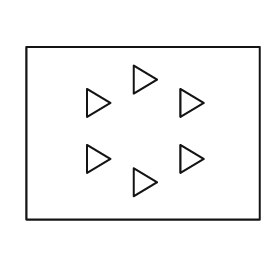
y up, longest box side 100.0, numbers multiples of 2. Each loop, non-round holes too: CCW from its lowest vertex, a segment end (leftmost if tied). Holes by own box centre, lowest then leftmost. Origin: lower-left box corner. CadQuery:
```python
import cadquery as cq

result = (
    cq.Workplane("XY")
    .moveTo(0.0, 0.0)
    .lineTo(100.0, 0.0)
    .lineTo(100.0, 74.0)
    .lineTo(0.0, 74.0)
    .close()
    .moveTo(46.0, 10.0)
    .lineTo(56.0, 16.0)
    .lineTo(46.0, 22.0)
    .close()
    .moveTo(26.0, 20.0)
    .lineTo(36.0, 26.0)
    .lineTo(26.0, 32.0)
    .close()
    .moveTo(66.0, 20.0)
    .lineTo(76.0, 26.0)
    .lineTo(66.0, 32.0)
    .close()
    .moveTo(26.0, 44.0)
    .lineTo(36.0, 50.0)
    .lineTo(26.0, 56.0)
    .close()
    .moveTo(66.0, 44.0)
    .lineTo(76.0, 50.0)
    .lineTo(66.0, 56.0)
    .close()
    .moveTo(46.0, 54.0)
    .lineTo(56.0, 60.0)
    .lineTo(46.0, 66.0)
    .close()
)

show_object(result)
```